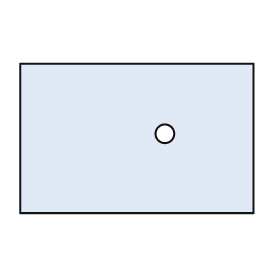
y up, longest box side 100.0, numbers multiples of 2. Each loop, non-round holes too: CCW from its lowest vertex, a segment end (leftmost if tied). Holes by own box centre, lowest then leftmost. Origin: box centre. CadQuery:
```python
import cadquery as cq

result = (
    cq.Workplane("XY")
    .moveTo(-50.0, -32.0)
    .lineTo(50.0, -32.0)
    .lineTo(50.0, 32.0)
    .lineTo(-50.0, 32.0)
    .close()
    .moveTo(12.0, 2.0)
    .circle(4.0)
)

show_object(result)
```